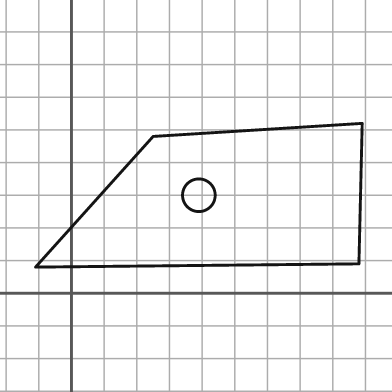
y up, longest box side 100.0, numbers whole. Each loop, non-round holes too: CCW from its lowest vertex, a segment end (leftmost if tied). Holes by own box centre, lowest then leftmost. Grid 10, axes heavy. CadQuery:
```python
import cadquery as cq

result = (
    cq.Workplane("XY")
    .moveTo(-11.0, 8.0)
    .lineTo(88.0, 9.0)
    .lineTo(89.0, 52.0)
    .lineTo(25.0, 48.0)
    .close()
    .moveTo(39.0, 30.0)
    .circle(5.0)
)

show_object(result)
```